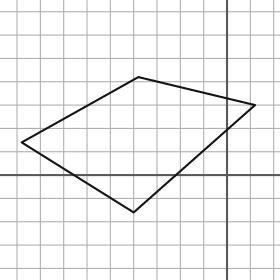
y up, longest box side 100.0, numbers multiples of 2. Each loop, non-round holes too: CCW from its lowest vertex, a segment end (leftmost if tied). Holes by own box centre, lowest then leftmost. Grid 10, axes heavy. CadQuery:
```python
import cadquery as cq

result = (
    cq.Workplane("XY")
    .moveTo(-40.0, -16.0)
    .lineTo(12.0, 30.0)
    .lineTo(-38.0, 42.0)
    .lineTo(-88.0, 14.0)
    .close()
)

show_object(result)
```